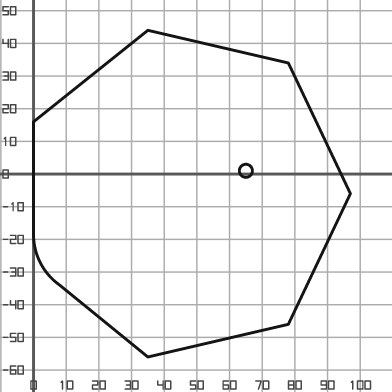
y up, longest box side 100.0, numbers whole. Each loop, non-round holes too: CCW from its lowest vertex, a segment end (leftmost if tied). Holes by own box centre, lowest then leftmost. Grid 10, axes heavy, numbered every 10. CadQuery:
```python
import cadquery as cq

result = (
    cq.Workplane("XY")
    .moveTo(35.0, -56.0)
    .lineTo(78.0, -46.0)
    .lineTo(97.0, -6.0)
    .lineTo(78.0, 34.0)
    .lineTo(35.0, 44.0)
    .lineTo(0.0, 16.0)
    .lineTo(0.0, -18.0)
    .threePointArc((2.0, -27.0), (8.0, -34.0))
    .close()
    .moveTo(65.0, 1.0)
    .circle(2.0)
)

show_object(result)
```